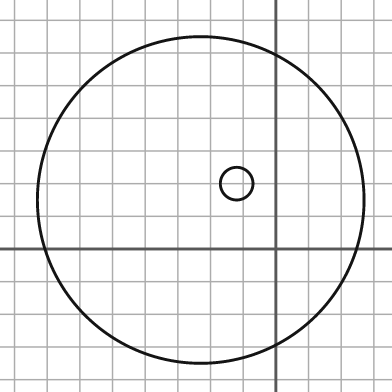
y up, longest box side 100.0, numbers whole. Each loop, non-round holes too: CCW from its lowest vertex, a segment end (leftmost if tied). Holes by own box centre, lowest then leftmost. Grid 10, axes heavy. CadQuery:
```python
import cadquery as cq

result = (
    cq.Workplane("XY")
    .moveTo(-23.0, 15.0)
    .circle(50.0)
    .moveTo(-12.0, 20.0)
    .circle(5.0)
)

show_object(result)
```